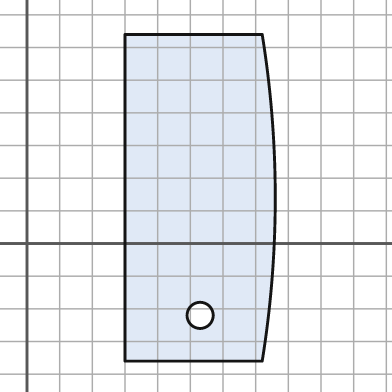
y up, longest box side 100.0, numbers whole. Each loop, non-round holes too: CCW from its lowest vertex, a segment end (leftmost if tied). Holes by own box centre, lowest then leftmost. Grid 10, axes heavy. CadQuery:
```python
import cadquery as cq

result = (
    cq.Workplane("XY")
    .moveTo(30.0, -36.0)
    .lineTo(72.0, -36.0)
    .threePointArc((76.0, 14.0), (72.0, 64.0))
    .lineTo(30.0, 64.0)
    .close()
    .moveTo(53.0, -22.0)
    .circle(4.0)
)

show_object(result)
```